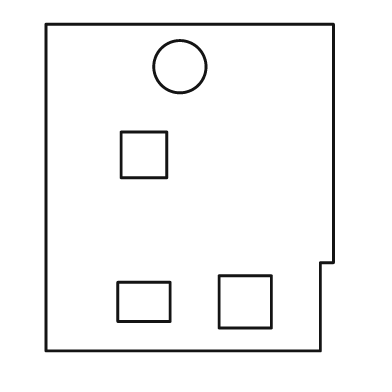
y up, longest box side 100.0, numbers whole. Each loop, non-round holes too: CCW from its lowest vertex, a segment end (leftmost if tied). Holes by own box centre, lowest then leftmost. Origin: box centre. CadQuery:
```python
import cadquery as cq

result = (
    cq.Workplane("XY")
    .moveTo(-44.0, -50.0)
    .lineTo(40.0, -50.0)
    .lineTo(40.0, -23.0)
    .lineTo(44.0, -23.0)
    .lineTo(44.0, 50.0)
    .lineTo(-44.0, 50.0)
    .close()
    .moveTo(-22.0, -41.0)
    .lineTo(-6.0, -41.0)
    .lineTo(-6.0, -29.0)
    .lineTo(-22.0, -29.0)
    .close()
    .moveTo(9.0, -43.0)
    .lineTo(25.0, -43.0)
    .lineTo(25.0, -27.0)
    .lineTo(9.0, -27.0)
    .close()
    .moveTo(-21.0, 3.0)
    .lineTo(-7.0, 3.0)
    .lineTo(-7.0, 17.0)
    .lineTo(-21.0, 17.0)
    .close()
    .moveTo(-3.0, 37.0)
    .circle(8.0)
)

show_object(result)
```